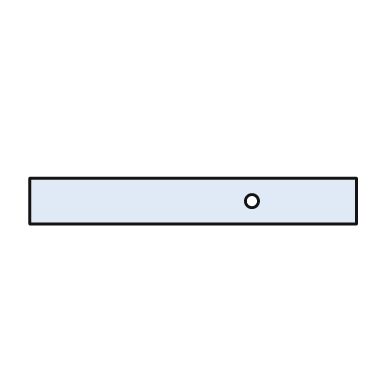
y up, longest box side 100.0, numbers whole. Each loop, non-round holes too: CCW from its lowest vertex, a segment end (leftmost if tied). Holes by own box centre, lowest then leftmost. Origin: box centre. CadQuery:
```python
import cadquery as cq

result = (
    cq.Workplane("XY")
    .moveTo(-50.0, -7.0)
    .lineTo(50.0, -7.0)
    .lineTo(50.0, 7.0)
    .lineTo(-50.0, 7.0)
    .close()
    .moveTo(18.0, 0.0)
    .circle(2.0)
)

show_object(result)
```